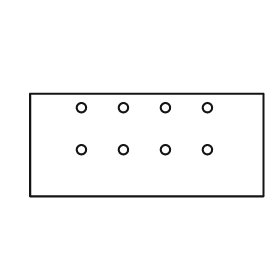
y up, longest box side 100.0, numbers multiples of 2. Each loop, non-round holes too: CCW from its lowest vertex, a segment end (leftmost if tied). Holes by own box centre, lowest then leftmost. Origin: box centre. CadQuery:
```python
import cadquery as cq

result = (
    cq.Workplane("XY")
    .moveTo(-50.0, -22.0)
    .lineTo(50.0, -22.0)
    .lineTo(50.0, 22.0)
    .lineTo(-50.0, 22.0)
    .close()
    .moveTo(-28.0, -2.0)
    .circle(2.0)
    .moveTo(-10.0, -2.0)
    .circle(2.0)
    .moveTo(8.0, -2.0)
    .circle(2.0)
    .moveTo(26.0, -2.0)
    .circle(2.0)
    .moveTo(-28.0, 16.0)
    .circle(2.0)
    .moveTo(-10.0, 16.0)
    .circle(2.0)
    .moveTo(8.0, 16.0)
    .circle(2.0)
    .moveTo(26.0, 16.0)
    .circle(2.0)
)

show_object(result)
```